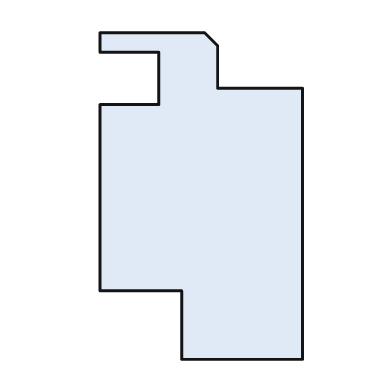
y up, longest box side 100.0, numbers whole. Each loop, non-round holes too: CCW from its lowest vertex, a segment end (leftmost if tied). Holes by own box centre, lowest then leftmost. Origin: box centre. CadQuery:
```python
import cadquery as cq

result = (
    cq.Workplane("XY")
    .moveTo(-6.0, -50.0)
    .lineTo(31.0, -50.0)
    .lineTo(31.0, 33.0)
    .lineTo(5.0, 33.0)
    .lineTo(5.0, 46.0)
    .lineTo(1.0, 50.0)
    .lineTo(-31.0, 50.0)
    .lineTo(-31.0, 44.0)
    .lineTo(-13.0, 44.0)
    .lineTo(-13.0, 28.0)
    .lineTo(-31.0, 28.0)
    .lineTo(-31.0, -29.0)
    .lineTo(-6.0, -29.0)
    .close()
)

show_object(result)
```